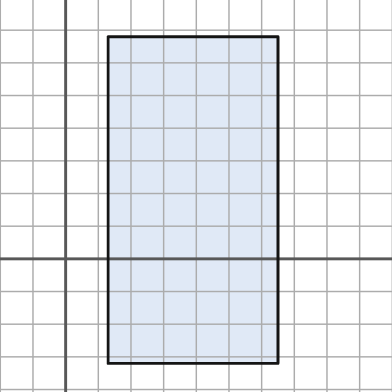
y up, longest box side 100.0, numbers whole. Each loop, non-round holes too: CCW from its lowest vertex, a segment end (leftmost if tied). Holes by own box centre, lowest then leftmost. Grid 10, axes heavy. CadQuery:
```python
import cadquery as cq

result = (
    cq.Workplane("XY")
    .moveTo(13.0, -32.0)
    .lineTo(65.0, -32.0)
    .lineTo(65.0, 68.0)
    .lineTo(13.0, 68.0)
    .close()
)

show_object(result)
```